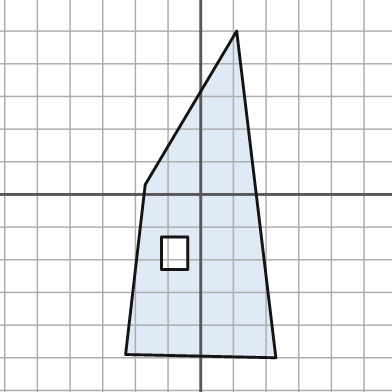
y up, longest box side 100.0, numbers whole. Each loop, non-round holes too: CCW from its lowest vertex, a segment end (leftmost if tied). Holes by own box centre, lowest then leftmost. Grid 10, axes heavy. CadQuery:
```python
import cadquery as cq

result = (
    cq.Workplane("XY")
    .moveTo(23.0, -50.0)
    .lineTo(11.0, 50.0)
    .lineTo(-17.0, 3.0)
    .lineTo(-23.0, -49.0)
    .close()
    .moveTo(-12.0, -23.0)
    .lineTo(-4.0, -23.0)
    .lineTo(-4.0, -13.0)
    .lineTo(-12.0, -13.0)
    .close()
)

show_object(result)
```